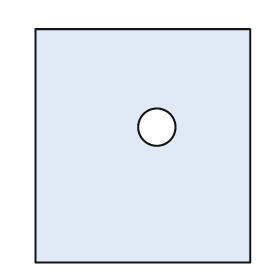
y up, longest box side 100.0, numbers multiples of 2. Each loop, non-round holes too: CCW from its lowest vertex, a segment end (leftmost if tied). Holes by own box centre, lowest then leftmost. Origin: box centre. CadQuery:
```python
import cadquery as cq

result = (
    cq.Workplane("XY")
    .moveTo(-46.0, -50.0)
    .lineTo(46.0, -50.0)
    .lineTo(46.0, 50.0)
    .lineTo(-46.0, 50.0)
    .close()
    .moveTo(6.0, 8.0)
    .circle(8.0)
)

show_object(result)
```